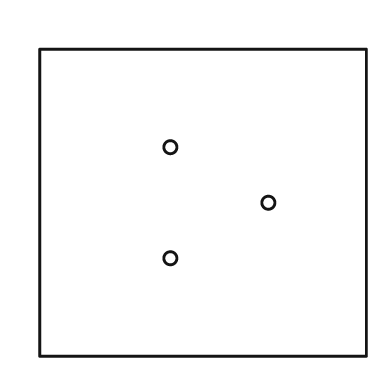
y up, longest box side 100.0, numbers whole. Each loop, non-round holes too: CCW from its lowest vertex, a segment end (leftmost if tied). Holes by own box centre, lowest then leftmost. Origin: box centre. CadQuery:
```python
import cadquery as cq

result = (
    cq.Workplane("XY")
    .moveTo(-50.0, -47.0)
    .lineTo(50.0, -47.0)
    .lineTo(50.0, 47.0)
    .lineTo(-50.0, 47.0)
    .close()
    .moveTo(-10.0, -17.0)
    .circle(2.0)
    .moveTo(20.0, 0.0)
    .circle(2.0)
    .moveTo(-10.0, 17.0)
    .circle(2.0)
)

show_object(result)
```